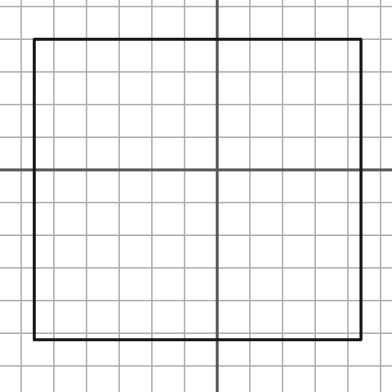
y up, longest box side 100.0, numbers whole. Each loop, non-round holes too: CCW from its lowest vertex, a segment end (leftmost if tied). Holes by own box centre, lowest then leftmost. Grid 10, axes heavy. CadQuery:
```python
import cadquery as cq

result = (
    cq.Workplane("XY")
    .moveTo(-56.0, -52.0)
    .lineTo(44.0, -52.0)
    .lineTo(44.0, 40.0)
    .lineTo(-56.0, 40.0)
    .close()
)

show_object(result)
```